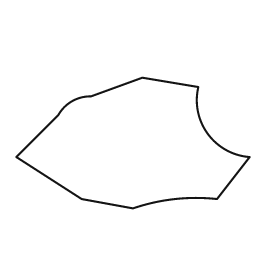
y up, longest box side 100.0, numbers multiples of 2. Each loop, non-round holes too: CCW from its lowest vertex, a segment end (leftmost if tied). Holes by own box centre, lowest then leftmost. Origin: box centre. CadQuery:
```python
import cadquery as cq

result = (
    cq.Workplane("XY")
    .moveTo(0.0, -28.0)
    .threePointArc((18.0, -24.0), (36.0, -24.0))
    .lineTo(50.0, -6.0)
    .threePointArc((32.0, 4.0), (28.0, 24.0))
    .lineTo(4.0, 28.0)
    .lineTo(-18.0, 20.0)
    .threePointArc((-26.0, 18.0), (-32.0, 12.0))
    .lineTo(-50.0, -6.0)
    .lineTo(-22.0, -24.0)
    .close()
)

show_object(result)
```